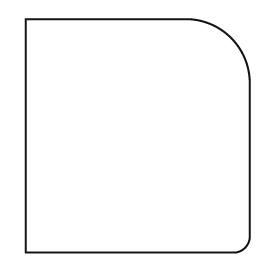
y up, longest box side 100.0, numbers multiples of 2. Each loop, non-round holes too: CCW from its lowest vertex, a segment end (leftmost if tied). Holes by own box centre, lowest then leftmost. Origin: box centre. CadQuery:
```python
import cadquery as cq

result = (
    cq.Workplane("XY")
    .moveTo(-48.0, -50.0)
    .lineTo(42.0, -50.0)
    .threePointArc((46.0, -48.0), (48.0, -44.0))
    .lineTo(48.0, 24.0)
    .threePointArc((40.0, 42.0), (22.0, 50.0))
    .lineTo(-48.0, 50.0)
    .close()
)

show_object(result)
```